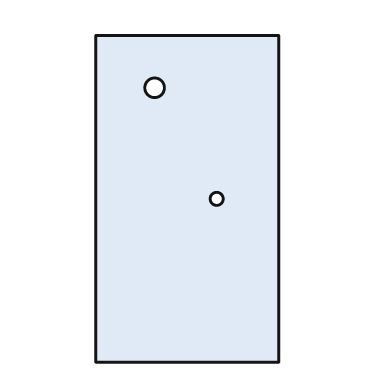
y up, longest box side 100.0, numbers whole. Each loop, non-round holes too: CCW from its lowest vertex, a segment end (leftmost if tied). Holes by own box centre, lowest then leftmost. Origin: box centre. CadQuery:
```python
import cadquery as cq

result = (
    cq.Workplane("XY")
    .moveTo(-28.0, -50.0)
    .lineTo(28.0, -50.0)
    .lineTo(28.0, 50.0)
    .lineTo(-28.0, 50.0)
    .close()
    .moveTo(9.0, 0.0)
    .circle(2.0)
    .moveTo(-10.0, 34.0)
    .circle(3.0)
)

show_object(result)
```